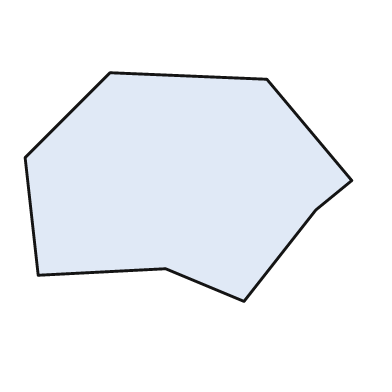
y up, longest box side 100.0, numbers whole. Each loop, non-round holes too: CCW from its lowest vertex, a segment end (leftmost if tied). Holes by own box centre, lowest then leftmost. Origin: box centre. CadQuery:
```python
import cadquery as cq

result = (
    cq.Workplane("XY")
    .moveTo(17.0, -35.0)
    .lineTo(39.0, -7.0)
    .lineTo(50.0, 2.0)
    .lineTo(24.0, 33.0)
    .lineTo(-24.0, 35.0)
    .lineTo(-50.0, 9.0)
    .lineTo(-46.0, -27.0)
    .lineTo(-7.0, -25.0)
    .close()
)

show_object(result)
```